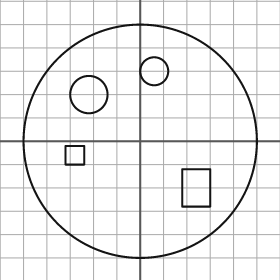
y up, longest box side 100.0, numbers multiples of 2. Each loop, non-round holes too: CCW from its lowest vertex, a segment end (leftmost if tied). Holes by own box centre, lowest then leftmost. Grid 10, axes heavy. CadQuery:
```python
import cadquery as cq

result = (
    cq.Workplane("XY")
    .moveTo(0.0, 0.0)
    .circle(50.0)
    .moveTo(18.0, -28.0)
    .lineTo(30.0, -28.0)
    .lineTo(30.0, -12.0)
    .lineTo(18.0, -12.0)
    .close()
    .moveTo(-32.0, -10.0)
    .lineTo(-24.0, -10.0)
    .lineTo(-24.0, -2.0)
    .lineTo(-32.0, -2.0)
    .close()
    .moveTo(-22.0, 20.0)
    .circle(8.0)
    .moveTo(6.0, 30.0)
    .circle(6.0)
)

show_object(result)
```